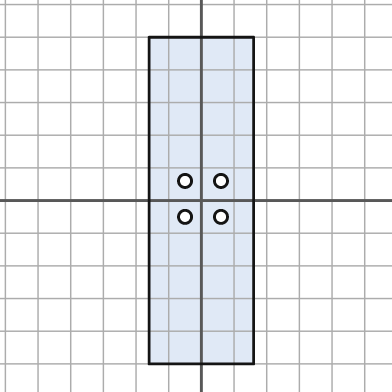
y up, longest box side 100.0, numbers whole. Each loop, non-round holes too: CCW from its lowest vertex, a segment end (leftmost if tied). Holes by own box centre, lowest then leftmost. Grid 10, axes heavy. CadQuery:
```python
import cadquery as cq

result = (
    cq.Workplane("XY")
    .moveTo(-16.0, -50.0)
    .lineTo(16.0, -50.0)
    .lineTo(16.0, 50.0)
    .lineTo(-16.0, 50.0)
    .close()
    .moveTo(-5.0, -5.0)
    .circle(2.0)
    .moveTo(6.0, -5.0)
    .circle(2.0)
    .moveTo(-5.0, 6.0)
    .circle(2.0)
    .moveTo(6.0, 6.0)
    .circle(2.0)
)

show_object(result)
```